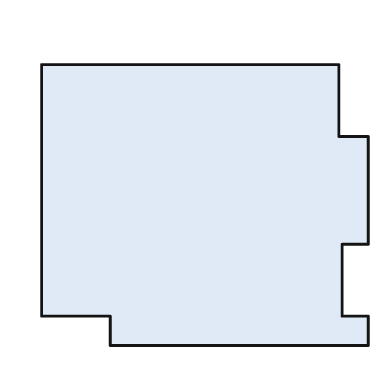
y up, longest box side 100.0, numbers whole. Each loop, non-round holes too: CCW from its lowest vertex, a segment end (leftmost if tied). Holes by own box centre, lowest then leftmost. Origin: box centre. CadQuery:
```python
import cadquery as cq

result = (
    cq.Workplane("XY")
    .moveTo(-29.0, -43.0)
    .lineTo(50.0, -43.0)
    .lineTo(50.0, -34.0)
    .lineTo(42.0, -34.0)
    .lineTo(42.0, -12.0)
    .lineTo(50.0, -12.0)
    .lineTo(50.0, 21.0)
    .lineTo(41.0, 21.0)
    .lineTo(41.0, 43.0)
    .lineTo(-50.0, 43.0)
    .lineTo(-50.0, -34.0)
    .lineTo(-29.0, -34.0)
    .close()
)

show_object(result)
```